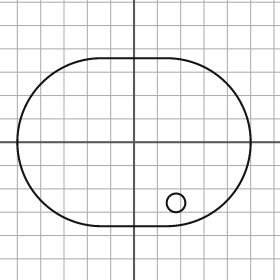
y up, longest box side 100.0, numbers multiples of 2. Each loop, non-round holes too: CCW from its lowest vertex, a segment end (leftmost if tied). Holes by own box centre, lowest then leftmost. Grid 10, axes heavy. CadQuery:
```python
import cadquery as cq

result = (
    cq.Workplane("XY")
    .moveTo(-14.0, -36.0)
    .lineTo(14.0, -36.0)
    .threePointArc((50.0, 0.0), (14.0, 36.0))
    .lineTo(-14.0, 36.0)
    .threePointArc((-50.0, 0.0), (-14.0, -36.0))
    .close()
    .moveTo(18.0, -26.0)
    .circle(4.0)
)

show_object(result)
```